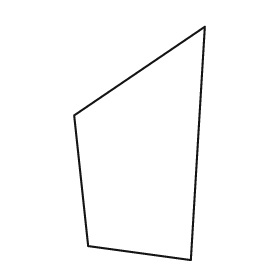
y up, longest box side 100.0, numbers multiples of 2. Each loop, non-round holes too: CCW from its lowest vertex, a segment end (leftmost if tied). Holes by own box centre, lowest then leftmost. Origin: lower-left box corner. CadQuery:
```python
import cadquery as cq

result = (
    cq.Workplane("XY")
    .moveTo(50.0, 0.0)
    .lineTo(56.0, 100.0)
    .lineTo(0.0, 62.0)
    .lineTo(6.0, 6.0)
    .close()
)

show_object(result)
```